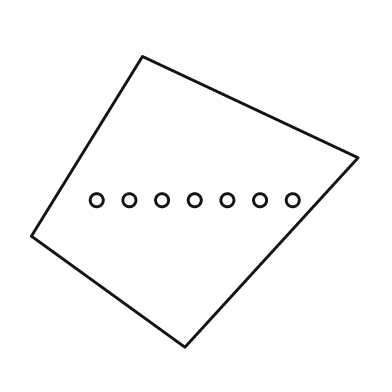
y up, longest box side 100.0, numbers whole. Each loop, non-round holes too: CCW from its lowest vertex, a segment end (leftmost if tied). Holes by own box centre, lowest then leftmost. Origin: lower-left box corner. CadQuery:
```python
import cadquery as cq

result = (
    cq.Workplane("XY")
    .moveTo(47.0, 0.0)
    .lineTo(100.0, 58.0)
    .lineTo(34.0, 89.0)
    .lineTo(0.0, 34.0)
    .close()
    .moveTo(20.0, 45.0)
    .circle(2.0)
    .moveTo(30.0, 45.0)
    .circle(2.0)
    .moveTo(40.0, 45.0)
    .circle(2.0)
    .moveTo(50.0, 45.0)
    .circle(2.0)
    .moveTo(60.0, 45.0)
    .circle(2.0)
    .moveTo(70.0, 45.0)
    .circle(2.0)
    .moveTo(80.0, 45.0)
    .circle(2.0)
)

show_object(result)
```